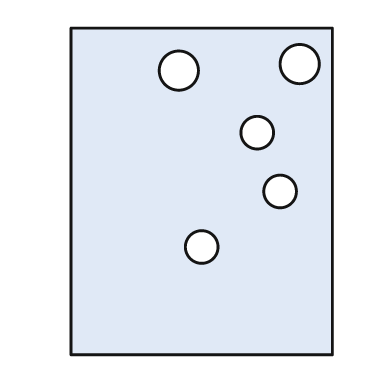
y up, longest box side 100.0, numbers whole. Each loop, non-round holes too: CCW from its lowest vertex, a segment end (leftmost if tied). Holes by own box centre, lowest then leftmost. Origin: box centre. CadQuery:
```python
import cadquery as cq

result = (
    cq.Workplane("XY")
    .moveTo(-40.0, -50.0)
    .lineTo(40.0, -50.0)
    .lineTo(40.0, 50.0)
    .lineTo(-40.0, 50.0)
    .close()
    .moveTo(0.0, -17.0)
    .circle(5.0)
    .moveTo(24.0, 0.0)
    .circle(5.0)
    .moveTo(17.0, 18.0)
    .circle(5.0)
    .moveTo(-7.0, 37.0)
    .circle(6.0)
    .moveTo(30.0, 39.0)
    .circle(6.0)
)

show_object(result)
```